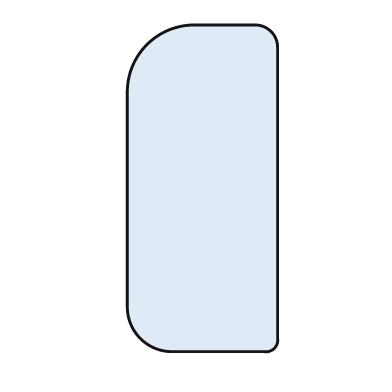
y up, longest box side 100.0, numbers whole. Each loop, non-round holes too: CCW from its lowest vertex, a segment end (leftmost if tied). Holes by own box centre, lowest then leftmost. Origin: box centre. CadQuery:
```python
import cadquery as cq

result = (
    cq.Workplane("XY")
    .moveTo(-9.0, -50.0)
    .lineTo(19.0, -50.0)
    .threePointArc((22.0, -49.0), (23.0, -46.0))
    .lineTo(23.0, 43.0)
    .threePointArc((21.0, 48.0), (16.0, 50.0))
    .lineTo(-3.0, 50.0)
    .threePointArc((-17.0, 44.0), (-23.0, 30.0))
    .lineTo(-23.0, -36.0)
    .threePointArc((-19.0, -46.0), (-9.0, -50.0))
    .close()
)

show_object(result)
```